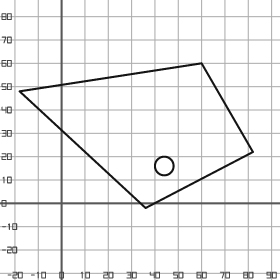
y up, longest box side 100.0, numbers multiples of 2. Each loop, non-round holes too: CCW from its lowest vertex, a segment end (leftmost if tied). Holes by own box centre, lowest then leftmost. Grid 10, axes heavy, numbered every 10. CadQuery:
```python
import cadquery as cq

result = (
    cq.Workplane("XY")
    .moveTo(36.0, -2.0)
    .lineTo(82.0, 22.0)
    .lineTo(60.0, 60.0)
    .lineTo(-18.0, 48.0)
    .close()
    .moveTo(44.0, 16.0)
    .circle(4.0)
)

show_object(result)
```